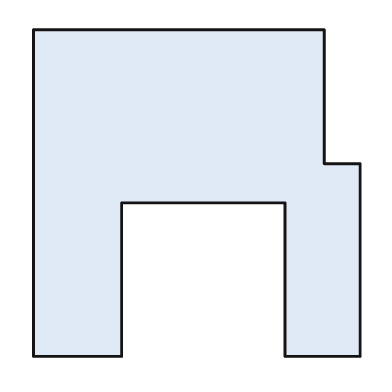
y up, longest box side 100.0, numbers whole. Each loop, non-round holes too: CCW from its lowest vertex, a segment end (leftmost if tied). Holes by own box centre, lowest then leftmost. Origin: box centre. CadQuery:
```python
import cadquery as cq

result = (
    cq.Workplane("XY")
    .moveTo(-50.0, -50.0)
    .lineTo(-23.0, -50.0)
    .lineTo(-23.0, -3.0)
    .lineTo(27.0, -3.0)
    .lineTo(27.0, -50.0)
    .lineTo(50.0, -50.0)
    .lineTo(50.0, 9.0)
    .lineTo(39.0, 9.0)
    .lineTo(39.0, 50.0)
    .lineTo(-50.0, 50.0)
    .close()
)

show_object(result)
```